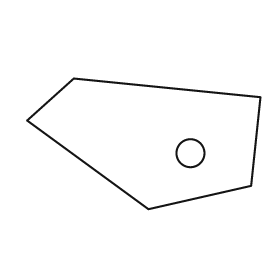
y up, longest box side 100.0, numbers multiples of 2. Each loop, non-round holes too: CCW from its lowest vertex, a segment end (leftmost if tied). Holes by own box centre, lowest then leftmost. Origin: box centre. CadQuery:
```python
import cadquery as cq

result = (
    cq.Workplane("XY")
    .moveTo(2.0, -28.0)
    .lineTo(46.0, -18.0)
    .lineTo(50.0, 20.0)
    .lineTo(-30.0, 28.0)
    .lineTo(-50.0, 10.0)
    .close()
    .moveTo(20.0, -4.0)
    .circle(6.0)
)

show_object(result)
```